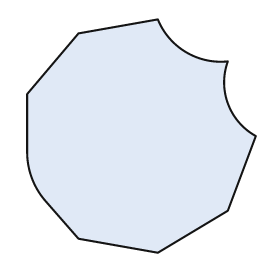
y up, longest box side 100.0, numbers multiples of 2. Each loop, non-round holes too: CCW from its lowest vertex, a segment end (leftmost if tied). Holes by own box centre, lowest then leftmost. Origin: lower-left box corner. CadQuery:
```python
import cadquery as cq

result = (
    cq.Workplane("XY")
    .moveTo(56.0, 0.0)
    .lineTo(86.0, 18.0)
    .lineTo(98.0, 50.0)
    .threePointArc((86.0, 64.0), (86.0, 82.0))
    .threePointArc((68.0, 86.0), (56.0, 100.0))
    .lineTo(22.0, 94.0)
    .lineTo(0.0, 68.0)
    .lineTo(0.0, 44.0)
    .threePointArc((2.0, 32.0), (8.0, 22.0))
    .lineTo(22.0, 6.0)
    .close()
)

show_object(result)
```